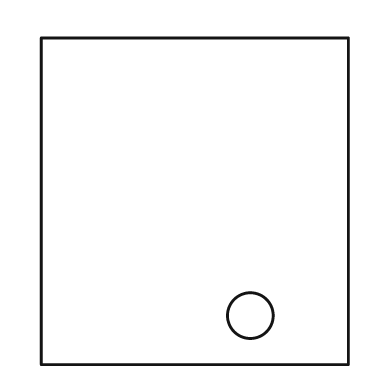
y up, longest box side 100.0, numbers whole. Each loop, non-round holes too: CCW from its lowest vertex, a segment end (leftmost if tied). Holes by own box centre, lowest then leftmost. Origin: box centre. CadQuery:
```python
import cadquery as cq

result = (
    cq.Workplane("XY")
    .moveTo(-47.0, -50.0)
    .lineTo(47.0, -50.0)
    .lineTo(47.0, 50.0)
    .lineTo(-47.0, 50.0)
    .close()
    .moveTo(17.0, -35.0)
    .circle(7.0)
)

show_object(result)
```